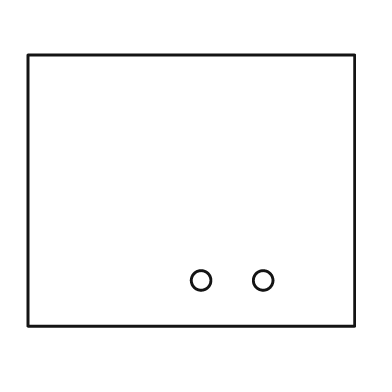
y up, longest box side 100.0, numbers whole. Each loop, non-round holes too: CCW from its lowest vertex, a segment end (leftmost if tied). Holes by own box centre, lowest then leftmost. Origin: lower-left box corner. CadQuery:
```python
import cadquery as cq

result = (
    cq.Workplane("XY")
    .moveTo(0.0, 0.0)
    .lineTo(100.0, 0.0)
    .lineTo(100.0, 83.0)
    .lineTo(0.0, 83.0)
    .close()
    .moveTo(53.0, 14.0)
    .circle(3.0)
    .moveTo(72.0, 14.0)
    .circle(3.0)
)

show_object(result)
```